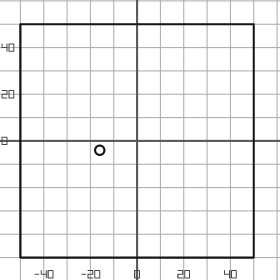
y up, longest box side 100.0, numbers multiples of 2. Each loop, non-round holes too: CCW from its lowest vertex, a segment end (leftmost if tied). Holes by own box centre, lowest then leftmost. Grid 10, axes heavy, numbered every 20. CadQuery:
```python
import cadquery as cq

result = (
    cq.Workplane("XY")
    .moveTo(-50.0, -50.0)
    .lineTo(50.0, -50.0)
    .lineTo(50.0, 50.0)
    .lineTo(-50.0, 50.0)
    .close()
    .moveTo(-16.0, -4.0)
    .circle(2.0)
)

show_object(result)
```